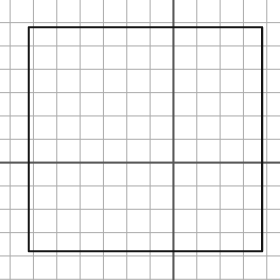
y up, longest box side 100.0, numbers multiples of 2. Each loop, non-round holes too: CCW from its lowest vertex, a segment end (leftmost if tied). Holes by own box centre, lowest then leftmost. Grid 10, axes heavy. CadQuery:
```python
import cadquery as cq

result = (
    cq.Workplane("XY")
    .moveTo(-62.0, -38.0)
    .lineTo(38.0, -38.0)
    .lineTo(38.0, 58.0)
    .lineTo(-62.0, 58.0)
    .close()
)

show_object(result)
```